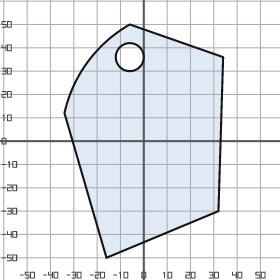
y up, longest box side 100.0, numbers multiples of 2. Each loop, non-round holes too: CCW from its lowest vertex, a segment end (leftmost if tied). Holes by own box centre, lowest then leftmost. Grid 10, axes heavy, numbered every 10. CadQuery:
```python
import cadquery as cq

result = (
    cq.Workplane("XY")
    .moveTo(-16.0, -50.0)
    .lineTo(32.0, -30.0)
    .lineTo(34.0, 36.0)
    .lineTo(-6.0, 50.0)
    .threePointArc((-24.0, 34.0), (-34.0, 12.0))
    .close()
    .moveTo(-6.0, 36.0)
    .circle(6.0)
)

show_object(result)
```